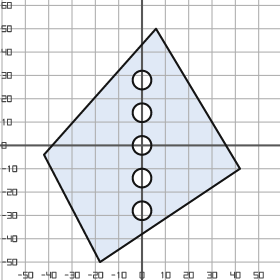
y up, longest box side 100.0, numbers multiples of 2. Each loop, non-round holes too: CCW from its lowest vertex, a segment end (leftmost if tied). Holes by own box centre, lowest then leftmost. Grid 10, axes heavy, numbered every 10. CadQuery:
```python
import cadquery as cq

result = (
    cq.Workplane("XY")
    .moveTo(-18.0, -50.0)
    .lineTo(42.0, -10.0)
    .lineTo(6.0, 50.0)
    .lineTo(-42.0, -4.0)
    .close()
    .moveTo(0.0, -28.0)
    .circle(4.0)
    .moveTo(0.0, -14.0)
    .circle(4.0)
    .moveTo(0.0, 0.0)
    .circle(4.0)
    .moveTo(0.0, 14.0)
    .circle(4.0)
    .moveTo(0.0, 28.0)
    .circle(4.0)
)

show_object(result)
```